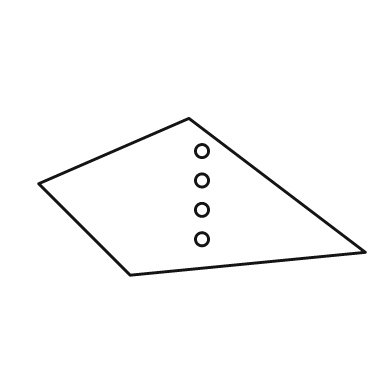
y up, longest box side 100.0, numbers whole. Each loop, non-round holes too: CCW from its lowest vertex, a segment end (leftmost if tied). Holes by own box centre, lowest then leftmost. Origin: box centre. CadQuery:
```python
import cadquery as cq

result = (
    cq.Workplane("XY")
    .moveTo(-22.0, -24.0)
    .lineTo(50.0, -17.0)
    .lineTo(-4.0, 24.0)
    .lineTo(-50.0, 4.0)
    .close()
    .moveTo(0.0, -13.0)
    .circle(2.0)
    .moveTo(0.0, -4.0)
    .circle(2.0)
    .moveTo(0.0, 5.0)
    .circle(2.0)
    .moveTo(0.0, 14.0)
    .circle(2.0)
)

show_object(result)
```